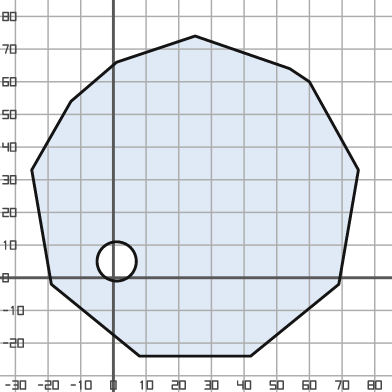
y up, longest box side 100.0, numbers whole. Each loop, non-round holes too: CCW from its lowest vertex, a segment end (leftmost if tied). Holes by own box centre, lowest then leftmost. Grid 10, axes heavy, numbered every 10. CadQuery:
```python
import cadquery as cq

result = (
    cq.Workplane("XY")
    .moveTo(8.0, -24.0)
    .lineTo(42.0, -24.0)
    .lineTo(69.0, -2.0)
    .lineTo(75.0, 33.0)
    .lineTo(60.0, 60.0)
    .lineTo(54.0, 64.0)
    .lineTo(25.0, 74.0)
    .lineTo(1.0, 66.0)
    .lineTo(-13.0, 54.0)
    .lineTo(-25.0, 33.0)
    .lineTo(-19.0, -2.0)
    .close()
    .moveTo(1.0, 5.0)
    .circle(6.0)
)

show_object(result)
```